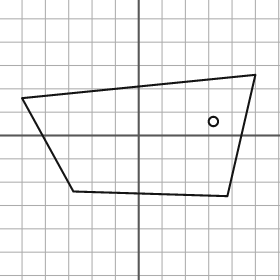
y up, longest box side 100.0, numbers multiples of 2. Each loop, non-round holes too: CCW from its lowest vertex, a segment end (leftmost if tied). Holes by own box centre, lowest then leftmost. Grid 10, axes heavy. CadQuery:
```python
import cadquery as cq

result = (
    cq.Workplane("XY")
    .moveTo(38.0, -26.0)
    .lineTo(50.0, 26.0)
    .lineTo(-50.0, 16.0)
    .lineTo(-28.0, -24.0)
    .close()
    .moveTo(32.0, 6.0)
    .circle(2.0)
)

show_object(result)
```